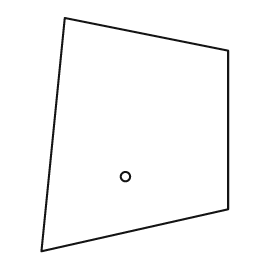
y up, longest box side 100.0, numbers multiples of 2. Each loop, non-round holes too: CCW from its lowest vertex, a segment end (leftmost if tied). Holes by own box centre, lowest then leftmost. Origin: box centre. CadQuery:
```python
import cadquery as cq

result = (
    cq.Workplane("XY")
    .moveTo(-40.0, -50.0)
    .lineTo(40.0, -32.0)
    .lineTo(40.0, 36.0)
    .lineTo(-30.0, 50.0)
    .close()
    .moveTo(-4.0, -18.0)
    .circle(2.0)
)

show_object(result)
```